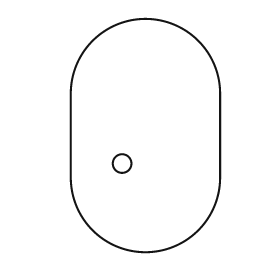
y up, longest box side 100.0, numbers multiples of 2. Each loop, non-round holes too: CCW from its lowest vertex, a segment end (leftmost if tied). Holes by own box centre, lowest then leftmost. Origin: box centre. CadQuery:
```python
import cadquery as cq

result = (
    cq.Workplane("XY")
    .moveTo(-32.0, -18.0)
    .threePointArc((0.0, -50.0), (32.0, -18.0))
    .lineTo(32.0, 18.0)
    .threePointArc((0.0, 50.0), (-32.0, 18.0))
    .close()
    .moveTo(-10.0, -12.0)
    .circle(4.0)
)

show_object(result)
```